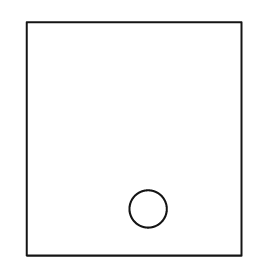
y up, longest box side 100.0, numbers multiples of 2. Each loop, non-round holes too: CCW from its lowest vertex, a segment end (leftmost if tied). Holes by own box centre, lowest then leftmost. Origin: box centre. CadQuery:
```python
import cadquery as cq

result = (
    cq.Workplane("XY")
    .moveTo(-46.0, -50.0)
    .lineTo(46.0, -50.0)
    .lineTo(46.0, 50.0)
    .lineTo(-46.0, 50.0)
    .close()
    .moveTo(6.0, -30.0)
    .circle(8.0)
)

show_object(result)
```